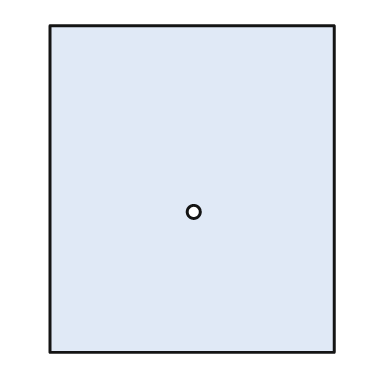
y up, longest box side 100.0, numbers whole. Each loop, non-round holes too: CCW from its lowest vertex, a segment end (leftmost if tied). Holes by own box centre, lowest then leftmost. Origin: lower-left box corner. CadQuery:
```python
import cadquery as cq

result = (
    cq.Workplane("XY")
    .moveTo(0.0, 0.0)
    .lineTo(87.0, 0.0)
    .lineTo(87.0, 100.0)
    .lineTo(0.0, 100.0)
    .close()
    .moveTo(44.0, 43.0)
    .circle(2.0)
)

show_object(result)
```